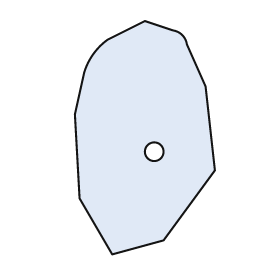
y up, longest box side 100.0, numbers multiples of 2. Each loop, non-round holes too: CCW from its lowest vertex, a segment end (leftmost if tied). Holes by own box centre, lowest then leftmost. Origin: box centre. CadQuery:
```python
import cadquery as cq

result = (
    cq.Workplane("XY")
    .moveTo(-14.0, -50.0)
    .lineTo(8.0, -44.0)
    .lineTo(30.0, -14.0)
    .lineTo(26.0, 22.0)
    .lineTo(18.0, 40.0)
    .threePointArc((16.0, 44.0), (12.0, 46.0))
    .lineTo(0.0, 50.0)
    .lineTo(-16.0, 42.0)
    .threePointArc((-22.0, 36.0), (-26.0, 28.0))
    .lineTo(-30.0, 10.0)
    .lineTo(-28.0, -26.0)
    .close()
    .moveTo(4.0, -6.0)
    .circle(4.0)
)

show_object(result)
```